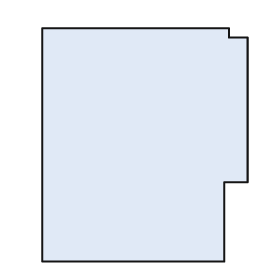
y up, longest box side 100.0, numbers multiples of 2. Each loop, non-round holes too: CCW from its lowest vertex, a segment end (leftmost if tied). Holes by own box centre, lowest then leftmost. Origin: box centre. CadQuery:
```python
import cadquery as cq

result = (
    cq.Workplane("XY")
    .moveTo(-44.0, -50.0)
    .lineTo(34.0, -50.0)
    .lineTo(34.0, -16.0)
    .lineTo(44.0, -16.0)
    .lineTo(44.0, 46.0)
    .lineTo(36.0, 46.0)
    .lineTo(36.0, 50.0)
    .lineTo(-44.0, 50.0)
    .close()
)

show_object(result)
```